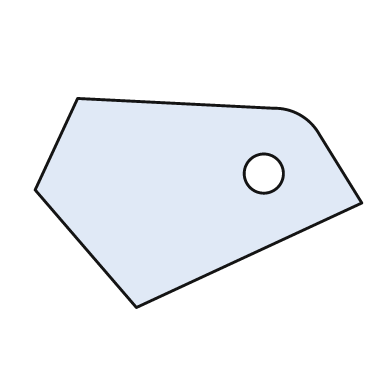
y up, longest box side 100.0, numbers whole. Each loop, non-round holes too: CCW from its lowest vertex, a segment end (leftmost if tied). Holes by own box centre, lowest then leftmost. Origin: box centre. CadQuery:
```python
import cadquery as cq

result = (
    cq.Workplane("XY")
    .moveTo(-19.0, -32.0)
    .lineTo(50.0, 0.0)
    .lineTo(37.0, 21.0)
    .threePointArc((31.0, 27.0), (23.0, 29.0))
    .lineTo(-37.0, 32.0)
    .lineTo(-50.0, 4.0)
    .close()
    .moveTo(20.0, 9.0)
    .circle(6.0)
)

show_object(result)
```